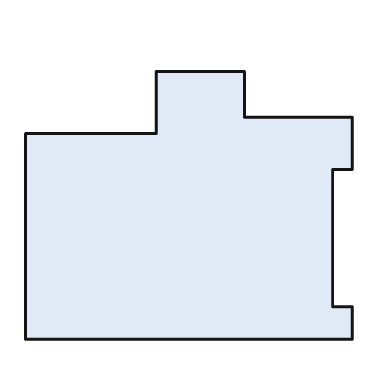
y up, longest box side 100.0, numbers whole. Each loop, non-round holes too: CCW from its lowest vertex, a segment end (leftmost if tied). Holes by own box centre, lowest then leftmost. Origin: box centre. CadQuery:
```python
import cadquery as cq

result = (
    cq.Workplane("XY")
    .moveTo(-50.0, -41.0)
    .lineTo(50.0, -41.0)
    .lineTo(50.0, -31.0)
    .lineTo(44.0, -31.0)
    .lineTo(44.0, 11.0)
    .lineTo(50.0, 11.0)
    .lineTo(50.0, 27.0)
    .lineTo(17.0, 27.0)
    .lineTo(17.0, 41.0)
    .lineTo(-10.0, 41.0)
    .lineTo(-10.0, 22.0)
    .lineTo(-50.0, 22.0)
    .close()
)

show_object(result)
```